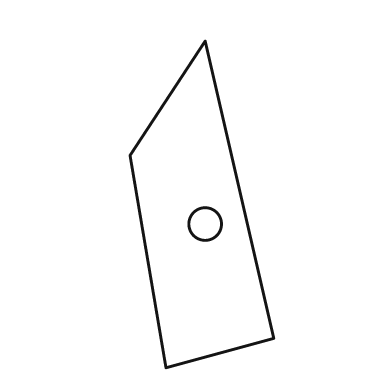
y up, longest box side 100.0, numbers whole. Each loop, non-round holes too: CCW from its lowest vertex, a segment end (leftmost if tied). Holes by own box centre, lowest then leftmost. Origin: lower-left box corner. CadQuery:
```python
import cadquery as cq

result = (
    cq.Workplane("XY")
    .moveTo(11.0, 0.0)
    .lineTo(44.0, 9.0)
    .lineTo(23.0, 100.0)
    .lineTo(0.0, 65.0)
    .close()
    .moveTo(23.0, 44.0)
    .circle(5.0)
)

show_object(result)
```